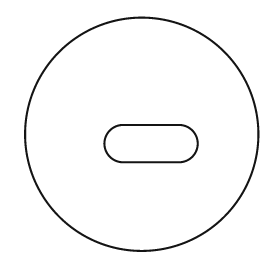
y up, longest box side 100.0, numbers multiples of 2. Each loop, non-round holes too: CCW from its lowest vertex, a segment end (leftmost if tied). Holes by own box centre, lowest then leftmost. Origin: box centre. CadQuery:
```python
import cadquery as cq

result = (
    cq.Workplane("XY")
    .moveTo(0.0, 0.0)
    .circle(50.0)
    .moveTo(-8.0, -12.0)
    .lineTo(16.0, -12.0)
    .threePointArc((24.0, -4.0), (16.0, 4.0))
    .lineTo(-8.0, 4.0)
    .threePointArc((-16.0, -4.0), (-8.0, -12.0))
    .close()
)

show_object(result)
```